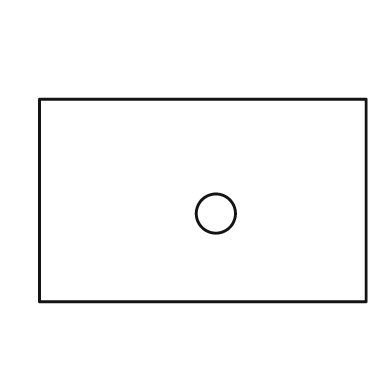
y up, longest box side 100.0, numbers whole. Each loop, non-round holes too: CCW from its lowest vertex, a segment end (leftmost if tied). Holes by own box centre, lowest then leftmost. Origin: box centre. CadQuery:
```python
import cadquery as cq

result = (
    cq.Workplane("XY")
    .moveTo(-50.0, -31.0)
    .lineTo(50.0, -31.0)
    .lineTo(50.0, 31.0)
    .lineTo(-50.0, 31.0)
    .close()
    .moveTo(4.0, -4.0)
    .circle(6.0)
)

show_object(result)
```